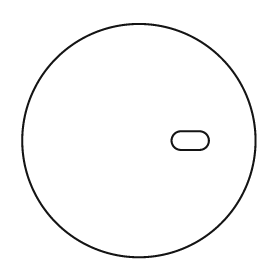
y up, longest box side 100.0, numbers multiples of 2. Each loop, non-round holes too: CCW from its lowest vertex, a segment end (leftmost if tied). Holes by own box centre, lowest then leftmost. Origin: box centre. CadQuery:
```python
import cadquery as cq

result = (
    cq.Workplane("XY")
    .moveTo(0.0, 0.0)
    .circle(50.0)
    .moveTo(18.0, -4.0)
    .lineTo(26.0, -4.0)
    .threePointArc((30.0, 0.0), (26.0, 4.0))
    .lineTo(18.0, 4.0)
    .threePointArc((14.0, 0.0), (18.0, -4.0))
    .close()
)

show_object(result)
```